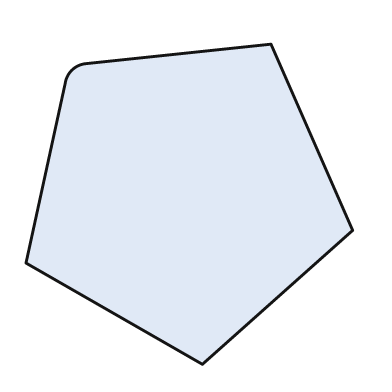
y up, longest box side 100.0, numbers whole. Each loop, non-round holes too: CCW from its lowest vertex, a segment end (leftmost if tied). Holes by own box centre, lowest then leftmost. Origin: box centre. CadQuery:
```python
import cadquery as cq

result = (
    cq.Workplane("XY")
    .moveTo(4.0, -49.0)
    .lineTo(50.0, -8.0)
    .lineTo(25.0, 49.0)
    .lineTo(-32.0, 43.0)
    .threePointArc((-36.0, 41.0), (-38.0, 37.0))
    .lineTo(-50.0, -18.0)
    .close()
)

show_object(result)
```